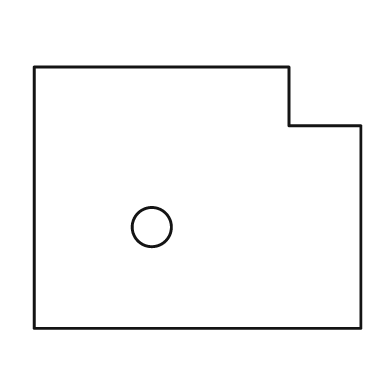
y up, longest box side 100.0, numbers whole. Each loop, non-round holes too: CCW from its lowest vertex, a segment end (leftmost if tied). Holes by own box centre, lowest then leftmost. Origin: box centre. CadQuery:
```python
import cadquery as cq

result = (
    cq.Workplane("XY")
    .moveTo(-50.0, -40.0)
    .lineTo(50.0, -40.0)
    .lineTo(50.0, 22.0)
    .lineTo(28.0, 22.0)
    .lineTo(28.0, 40.0)
    .lineTo(-50.0, 40.0)
    .close()
    .moveTo(-14.0, -9.0)
    .circle(6.0)
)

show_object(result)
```